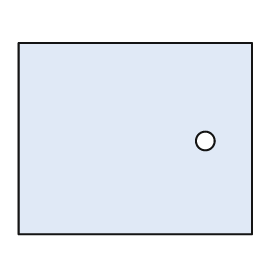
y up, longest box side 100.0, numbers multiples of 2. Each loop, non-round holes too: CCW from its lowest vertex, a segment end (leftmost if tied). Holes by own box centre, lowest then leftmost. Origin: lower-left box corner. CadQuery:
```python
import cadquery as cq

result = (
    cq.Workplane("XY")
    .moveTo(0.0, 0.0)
    .lineTo(100.0, 0.0)
    .lineTo(100.0, 82.0)
    .lineTo(0.0, 82.0)
    .close()
    .moveTo(80.0, 40.0)
    .circle(4.0)
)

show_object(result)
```